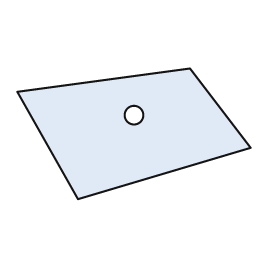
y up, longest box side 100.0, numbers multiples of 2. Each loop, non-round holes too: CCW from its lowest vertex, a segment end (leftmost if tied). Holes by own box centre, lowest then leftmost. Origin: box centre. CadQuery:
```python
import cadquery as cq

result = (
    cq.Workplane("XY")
    .moveTo(-24.0, -28.0)
    .lineTo(50.0, -6.0)
    .lineTo(24.0, 28.0)
    .lineTo(-50.0, 18.0)
    .close()
    .moveTo(0.0, 8.0)
    .circle(4.0)
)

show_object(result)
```